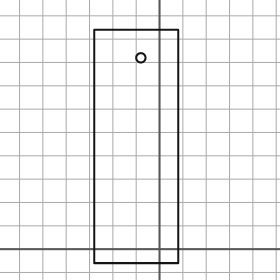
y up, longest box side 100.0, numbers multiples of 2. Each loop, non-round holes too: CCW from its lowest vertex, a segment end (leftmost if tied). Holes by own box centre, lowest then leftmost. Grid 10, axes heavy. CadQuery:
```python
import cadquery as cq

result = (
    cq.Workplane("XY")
    .moveTo(-28.0, -6.0)
    .lineTo(8.0, -6.0)
    .lineTo(8.0, 94.0)
    .lineTo(-28.0, 94.0)
    .close()
    .moveTo(-8.0, 82.0)
    .circle(2.0)
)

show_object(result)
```